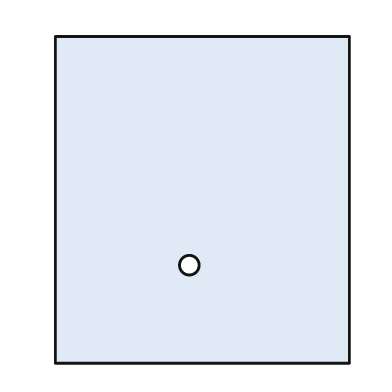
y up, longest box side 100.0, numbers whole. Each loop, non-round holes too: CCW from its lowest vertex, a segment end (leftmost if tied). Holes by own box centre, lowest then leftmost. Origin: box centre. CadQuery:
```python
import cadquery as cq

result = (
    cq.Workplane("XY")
    .moveTo(-45.0, -50.0)
    .lineTo(45.0, -50.0)
    .lineTo(45.0, 50.0)
    .lineTo(-45.0, 50.0)
    .close()
    .moveTo(-4.0, -20.0)
    .circle(3.0)
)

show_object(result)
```